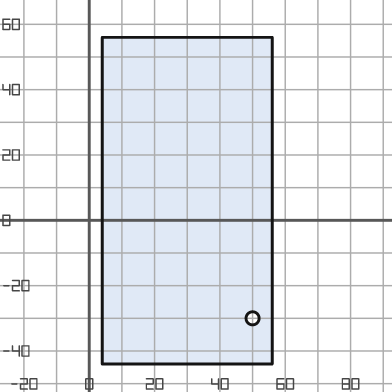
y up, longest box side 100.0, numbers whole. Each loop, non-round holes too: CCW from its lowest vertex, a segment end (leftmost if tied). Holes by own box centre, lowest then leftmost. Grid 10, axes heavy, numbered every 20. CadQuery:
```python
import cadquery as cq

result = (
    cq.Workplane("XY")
    .moveTo(4.0, -44.0)
    .lineTo(56.0, -44.0)
    .lineTo(56.0, 56.0)
    .lineTo(4.0, 56.0)
    .close()
    .moveTo(50.0, -30.0)
    .circle(2.0)
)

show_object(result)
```